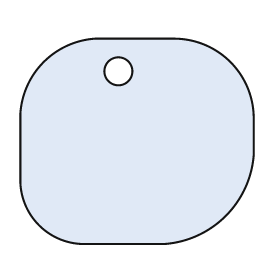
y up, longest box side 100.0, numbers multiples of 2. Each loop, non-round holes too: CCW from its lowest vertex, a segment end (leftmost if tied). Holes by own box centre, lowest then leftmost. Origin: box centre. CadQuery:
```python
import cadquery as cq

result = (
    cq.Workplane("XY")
    .moveTo(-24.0, -44.0)
    .lineTo(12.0, -44.0)
    .threePointArc((38.0, -32.0), (50.0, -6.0))
    .lineTo(50.0, 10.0)
    .threePointArc((40.0, 34.0), (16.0, 44.0))
    .lineTo(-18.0, 44.0)
    .threePointArc((-40.0, 34.0), (-50.0, 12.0))
    .lineTo(-50.0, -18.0)
    .threePointArc((-42.0, -36.0), (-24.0, -44.0))
    .close()
    .moveTo(-8.0, 30.0)
    .circle(6.0)
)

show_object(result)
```